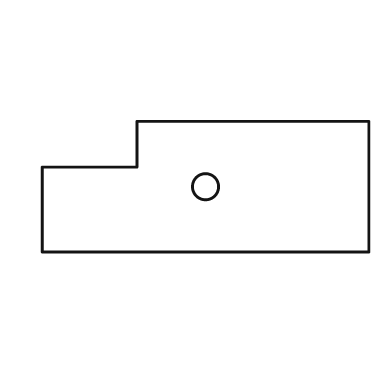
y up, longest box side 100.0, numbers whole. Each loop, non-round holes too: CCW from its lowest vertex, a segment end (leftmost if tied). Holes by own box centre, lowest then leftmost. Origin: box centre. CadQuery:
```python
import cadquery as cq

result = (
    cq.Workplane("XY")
    .moveTo(-50.0, -20.0)
    .lineTo(50.0, -20.0)
    .lineTo(50.0, 20.0)
    .lineTo(-21.0, 20.0)
    .lineTo(-21.0, 6.0)
    .lineTo(-50.0, 6.0)
    .close()
    .moveTo(0.0, 0.0)
    .circle(4.0)
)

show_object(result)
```